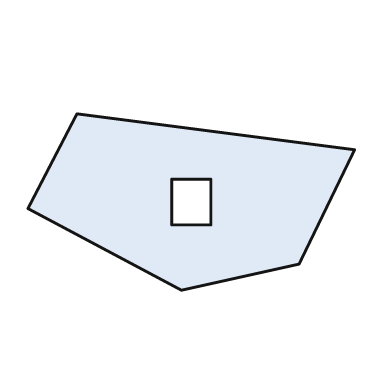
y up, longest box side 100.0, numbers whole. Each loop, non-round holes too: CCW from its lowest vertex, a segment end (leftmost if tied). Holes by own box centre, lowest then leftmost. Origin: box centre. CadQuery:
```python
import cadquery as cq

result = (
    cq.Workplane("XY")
    .moveTo(-3.0, -27.0)
    .lineTo(33.0, -19.0)
    .lineTo(50.0, 16.0)
    .lineTo(-35.0, 27.0)
    .lineTo(-50.0, -2.0)
    .close()
    .moveTo(-6.0, -7.0)
    .lineTo(6.0, -7.0)
    .lineTo(6.0, 7.0)
    .lineTo(-6.0, 7.0)
    .close()
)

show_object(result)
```